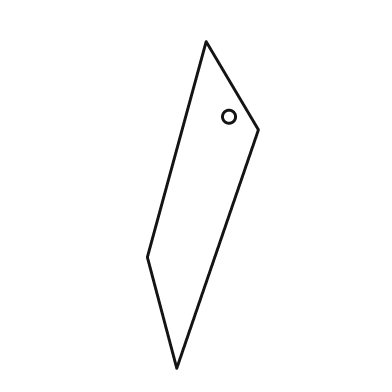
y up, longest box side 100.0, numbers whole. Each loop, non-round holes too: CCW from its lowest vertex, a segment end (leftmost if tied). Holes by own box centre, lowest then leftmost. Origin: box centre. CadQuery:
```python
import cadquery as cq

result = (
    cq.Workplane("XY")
    .moveTo(-8.0, -50.0)
    .lineTo(17.0, 23.0)
    .lineTo(1.0, 50.0)
    .lineTo(-17.0, -16.0)
    .close()
    .moveTo(8.0, 27.0)
    .circle(2.0)
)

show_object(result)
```